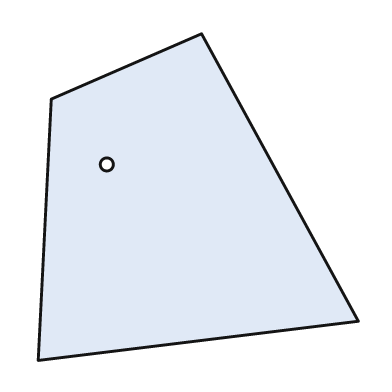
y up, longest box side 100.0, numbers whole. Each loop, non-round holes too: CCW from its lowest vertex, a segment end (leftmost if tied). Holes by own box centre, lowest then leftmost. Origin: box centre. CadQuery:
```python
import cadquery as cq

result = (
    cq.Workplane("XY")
    .moveTo(-49.0, -50.0)
    .lineTo(49.0, -38.0)
    .lineTo(1.0, 50.0)
    .lineTo(-45.0, 30.0)
    .close()
    .moveTo(-28.0, 10.0)
    .circle(2.0)
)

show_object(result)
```